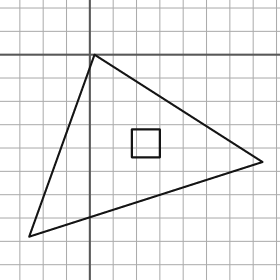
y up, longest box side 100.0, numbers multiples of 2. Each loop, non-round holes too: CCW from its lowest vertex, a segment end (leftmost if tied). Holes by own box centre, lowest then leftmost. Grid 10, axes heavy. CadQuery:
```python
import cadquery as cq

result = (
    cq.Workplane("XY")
    .moveTo(-26.0, -78.0)
    .lineTo(74.0, -46.0)
    .lineTo(2.0, 0.0)
    .close()
    .moveTo(18.0, -44.0)
    .lineTo(30.0, -44.0)
    .lineTo(30.0, -32.0)
    .lineTo(18.0, -32.0)
    .close()
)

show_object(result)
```